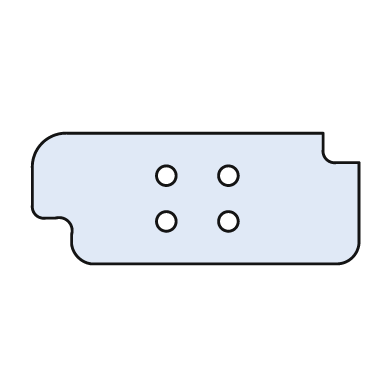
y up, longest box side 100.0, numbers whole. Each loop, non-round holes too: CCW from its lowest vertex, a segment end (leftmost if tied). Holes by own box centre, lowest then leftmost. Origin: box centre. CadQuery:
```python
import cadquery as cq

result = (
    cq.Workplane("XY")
    .moveTo(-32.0, -20.0)
    .lineTo(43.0, -20.0)
    .threePointArc((48.0, -18.0), (50.0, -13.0))
    .lineTo(50.0, 11.0)
    .lineTo(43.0, 11.0)
    .threePointArc((40.0, 12.0), (39.0, 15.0))
    .lineTo(39.0, 20.0)
    .lineTo(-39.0, 20.0)
    .threePointArc((-47.0, 17.0), (-50.0, 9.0))
    .lineTo(-50.0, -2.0)
    .threePointArc((-49.0, -5.0), (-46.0, -6.0))
    .lineTo(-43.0, -6.0)
    .threePointArc((-39.0, -7.0), (-38.0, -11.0))
    .lineTo(-38.0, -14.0)
    .threePointArc((-36.0, -18.0), (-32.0, -20.0))
    .close()
    .moveTo(-9.0, -7.0)
    .circle(3.0)
    .moveTo(10.0, -7.0)
    .circle(3.0)
    .moveTo(-9.0, 7.0)
    .circle(3.0)
    .moveTo(10.0, 7.0)
    .circle(3.0)
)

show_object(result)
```